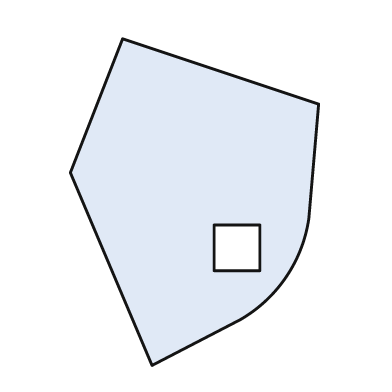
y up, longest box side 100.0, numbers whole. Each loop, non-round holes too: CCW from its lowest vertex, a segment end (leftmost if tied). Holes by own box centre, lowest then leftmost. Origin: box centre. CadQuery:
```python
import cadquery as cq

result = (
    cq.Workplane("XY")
    .moveTo(-13.0, -50.0)
    .lineTo(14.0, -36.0)
    .threePointArc((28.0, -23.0), (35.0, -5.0))
    .lineTo(38.0, 30.0)
    .lineTo(-22.0, 50.0)
    .lineTo(-38.0, 9.0)
    .close()
    .moveTo(6.0, -21.0)
    .lineTo(20.0, -21.0)
    .lineTo(20.0, -7.0)
    .lineTo(6.0, -7.0)
    .close()
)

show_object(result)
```